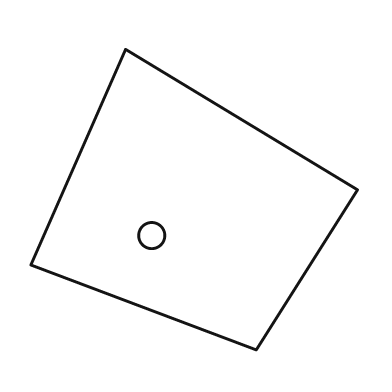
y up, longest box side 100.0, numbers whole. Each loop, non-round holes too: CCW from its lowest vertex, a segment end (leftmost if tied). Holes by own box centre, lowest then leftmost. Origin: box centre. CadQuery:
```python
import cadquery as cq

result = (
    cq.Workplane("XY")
    .moveTo(19.0, -46.0)
    .lineTo(50.0, 3.0)
    .lineTo(-21.0, 46.0)
    .lineTo(-50.0, -20.0)
    .close()
    .moveTo(-13.0, -11.0)
    .circle(4.0)
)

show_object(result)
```